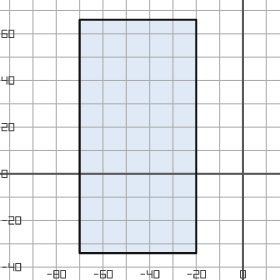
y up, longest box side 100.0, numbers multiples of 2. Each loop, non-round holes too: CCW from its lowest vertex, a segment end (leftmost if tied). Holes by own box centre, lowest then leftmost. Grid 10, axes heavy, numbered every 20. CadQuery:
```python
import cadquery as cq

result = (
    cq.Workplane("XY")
    .moveTo(-70.0, -34.0)
    .lineTo(-20.0, -34.0)
    .lineTo(-20.0, 66.0)
    .lineTo(-70.0, 66.0)
    .close()
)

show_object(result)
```